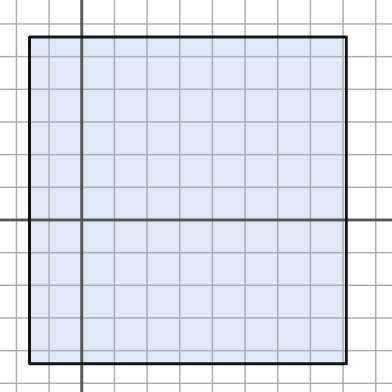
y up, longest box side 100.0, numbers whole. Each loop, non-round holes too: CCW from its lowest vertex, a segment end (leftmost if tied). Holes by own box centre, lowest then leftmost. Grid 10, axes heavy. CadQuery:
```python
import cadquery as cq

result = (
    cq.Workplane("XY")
    .moveTo(-16.0, -44.0)
    .lineTo(81.0, -44.0)
    .lineTo(81.0, 56.0)
    .lineTo(-16.0, 56.0)
    .close()
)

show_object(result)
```